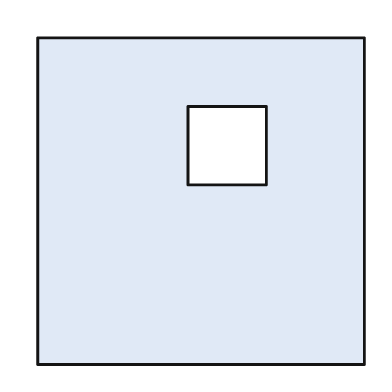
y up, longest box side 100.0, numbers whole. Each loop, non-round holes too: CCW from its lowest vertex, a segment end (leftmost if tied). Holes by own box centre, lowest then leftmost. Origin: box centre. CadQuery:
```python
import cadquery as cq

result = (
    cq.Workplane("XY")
    .moveTo(-50.0, -50.0)
    .lineTo(50.0, -50.0)
    .lineTo(50.0, 50.0)
    .lineTo(-50.0, 50.0)
    .close()
    .moveTo(-4.0, 5.0)
    .lineTo(20.0, 5.0)
    .lineTo(20.0, 29.0)
    .lineTo(-4.0, 29.0)
    .close()
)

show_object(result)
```